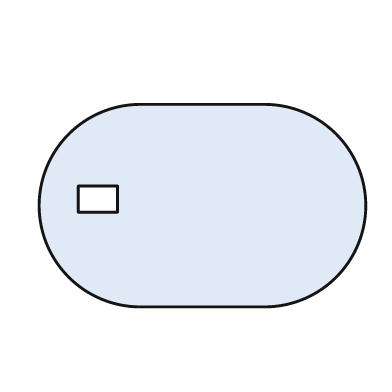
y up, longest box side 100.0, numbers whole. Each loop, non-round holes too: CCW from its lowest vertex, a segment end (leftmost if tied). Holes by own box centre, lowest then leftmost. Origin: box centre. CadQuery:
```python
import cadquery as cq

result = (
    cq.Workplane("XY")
    .moveTo(-19.0, -31.0)
    .lineTo(19.0, -31.0)
    .threePointArc((50.0, 0.0), (19.0, 31.0))
    .lineTo(-19.0, 31.0)
    .threePointArc((-50.0, 0.0), (-19.0, -31.0))
    .close()
    .moveTo(-38.0, -2.0)
    .lineTo(-26.0, -2.0)
    .lineTo(-26.0, 6.0)
    .lineTo(-38.0, 6.0)
    .close()
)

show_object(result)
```